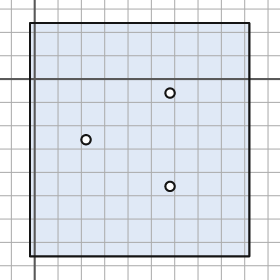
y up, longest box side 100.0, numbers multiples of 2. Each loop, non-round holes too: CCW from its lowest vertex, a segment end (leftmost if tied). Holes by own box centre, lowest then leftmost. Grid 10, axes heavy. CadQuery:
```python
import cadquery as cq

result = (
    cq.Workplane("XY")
    .moveTo(-2.0, -76.0)
    .lineTo(92.0, -76.0)
    .lineTo(92.0, 24.0)
    .lineTo(-2.0, 24.0)
    .close()
    .moveTo(58.0, -46.0)
    .circle(2.0)
    .moveTo(22.0, -26.0)
    .circle(2.0)
    .moveTo(58.0, -6.0)
    .circle(2.0)
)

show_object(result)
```